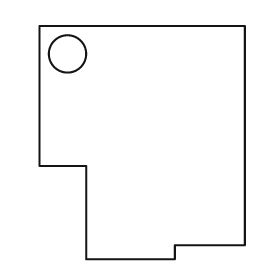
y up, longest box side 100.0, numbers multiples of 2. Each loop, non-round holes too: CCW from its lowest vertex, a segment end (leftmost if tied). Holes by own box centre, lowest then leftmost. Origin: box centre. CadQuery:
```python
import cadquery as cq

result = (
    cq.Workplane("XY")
    .moveTo(-24.0, -50.0)
    .lineTo(14.0, -50.0)
    .lineTo(14.0, -44.0)
    .lineTo(44.0, -44.0)
    .lineTo(44.0, 50.0)
    .lineTo(-44.0, 50.0)
    .lineTo(-44.0, -10.0)
    .lineTo(-24.0, -10.0)
    .close()
    .moveTo(-32.0, 38.0)
    .circle(8.0)
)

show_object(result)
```